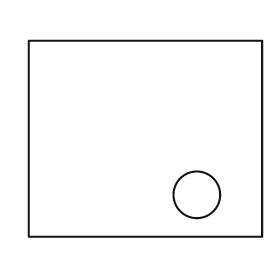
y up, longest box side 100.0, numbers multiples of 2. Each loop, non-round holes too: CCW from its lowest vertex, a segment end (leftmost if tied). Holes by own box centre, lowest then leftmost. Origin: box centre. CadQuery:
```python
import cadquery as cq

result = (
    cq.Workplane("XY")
    .moveTo(-50.0, -42.0)
    .lineTo(50.0, -42.0)
    .lineTo(50.0, 42.0)
    .lineTo(-50.0, 42.0)
    .close()
    .moveTo(22.0, -24.0)
    .circle(10.0)
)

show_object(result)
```